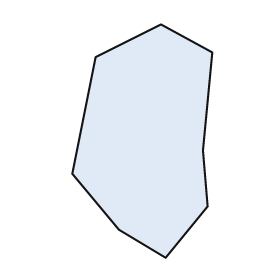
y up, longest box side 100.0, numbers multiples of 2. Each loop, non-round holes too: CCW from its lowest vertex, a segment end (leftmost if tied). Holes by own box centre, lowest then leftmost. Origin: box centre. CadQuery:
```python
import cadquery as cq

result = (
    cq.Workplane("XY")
    .moveTo(10.0, -50.0)
    .lineTo(28.0, -28.0)
    .lineTo(26.0, -4.0)
    .lineTo(30.0, 38.0)
    .lineTo(8.0, 50.0)
    .lineTo(-20.0, 36.0)
    .lineTo(-30.0, -14.0)
    .lineTo(-10.0, -38.0)
    .close()
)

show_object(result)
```